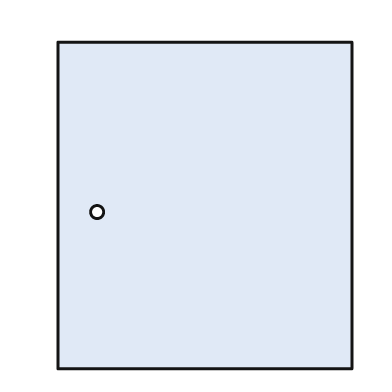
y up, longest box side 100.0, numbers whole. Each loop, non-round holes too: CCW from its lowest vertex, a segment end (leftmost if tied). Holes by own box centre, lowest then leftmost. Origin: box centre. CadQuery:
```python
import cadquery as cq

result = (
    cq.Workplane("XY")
    .moveTo(-45.0, -50.0)
    .lineTo(45.0, -50.0)
    .lineTo(45.0, 50.0)
    .lineTo(-45.0, 50.0)
    .close()
    .moveTo(-33.0, -2.0)
    .circle(2.0)
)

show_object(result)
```